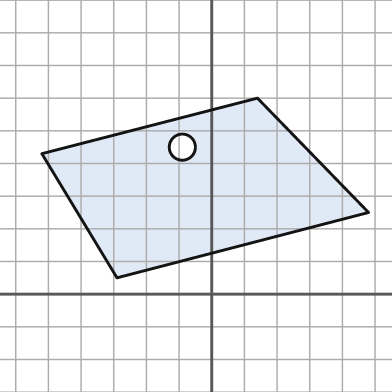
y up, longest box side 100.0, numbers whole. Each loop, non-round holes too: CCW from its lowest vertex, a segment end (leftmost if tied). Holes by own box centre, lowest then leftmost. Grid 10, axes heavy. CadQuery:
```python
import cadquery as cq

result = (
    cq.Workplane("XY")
    .moveTo(-29.0, 5.0)
    .lineTo(48.0, 25.0)
    .lineTo(14.0, 60.0)
    .lineTo(-52.0, 43.0)
    .close()
    .moveTo(-9.0, 45.0)
    .circle(4.0)
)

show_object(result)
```